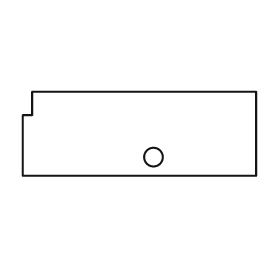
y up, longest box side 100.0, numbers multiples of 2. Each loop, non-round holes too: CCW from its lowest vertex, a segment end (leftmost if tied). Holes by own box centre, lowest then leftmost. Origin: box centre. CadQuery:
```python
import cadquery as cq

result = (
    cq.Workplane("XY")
    .moveTo(-50.0, -18.0)
    .lineTo(50.0, -18.0)
    .lineTo(50.0, 18.0)
    .lineTo(-46.0, 18.0)
    .lineTo(-46.0, 8.0)
    .lineTo(-50.0, 8.0)
    .close()
    .moveTo(6.0, -10.0)
    .circle(4.0)
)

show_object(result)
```